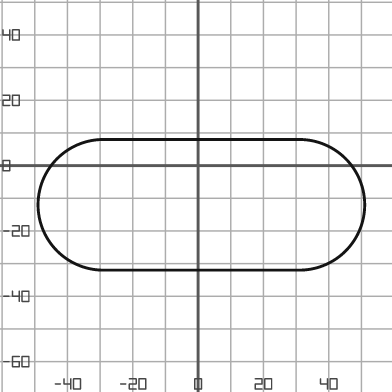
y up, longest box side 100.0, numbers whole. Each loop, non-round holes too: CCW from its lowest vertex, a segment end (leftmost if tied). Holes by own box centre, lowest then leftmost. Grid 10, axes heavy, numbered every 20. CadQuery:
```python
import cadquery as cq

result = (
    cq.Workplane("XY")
    .moveTo(-29.0, -32.0)
    .lineTo(31.0, -32.0)
    .threePointArc((51.0, -12.0), (31.0, 8.0))
    .lineTo(-29.0, 8.0)
    .threePointArc((-49.0, -12.0), (-29.0, -32.0))
    .close()
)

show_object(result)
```